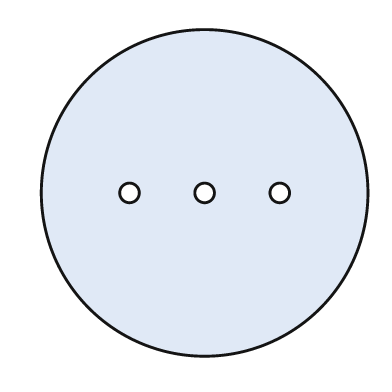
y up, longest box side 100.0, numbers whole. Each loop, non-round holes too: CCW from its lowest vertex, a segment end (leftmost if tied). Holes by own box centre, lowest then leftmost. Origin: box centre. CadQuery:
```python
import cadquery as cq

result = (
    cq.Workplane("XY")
    .moveTo(0.0, 0.0)
    .circle(50.0)
    .moveTo(-23.0, 0.0)
    .circle(3.0)
    .moveTo(0.0, 0.0)
    .circle(3.0)
    .moveTo(23.0, 0.0)
    .circle(3.0)
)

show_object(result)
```